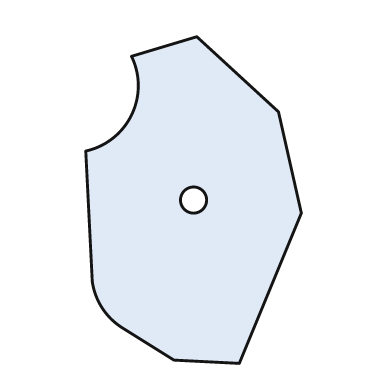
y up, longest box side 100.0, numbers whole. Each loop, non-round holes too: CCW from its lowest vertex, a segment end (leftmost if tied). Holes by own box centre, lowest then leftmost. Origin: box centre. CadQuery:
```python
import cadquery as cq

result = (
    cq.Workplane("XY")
    .moveTo(14.0, -50.0)
    .lineTo(33.0, -4.0)
    .lineTo(26.0, 27.0)
    .lineTo(1.0, 50.0)
    .lineTo(-19.0, 44.0)
    .threePointArc((-19.0, 26.0), (-33.0, 15.0))
    .lineTo(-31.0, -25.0)
    .threePointArc((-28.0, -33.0), (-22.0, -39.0))
    .lineTo(-6.0, -49.0)
    .close()
    .moveTo(0.0, 0.0)
    .circle(4.0)
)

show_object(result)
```